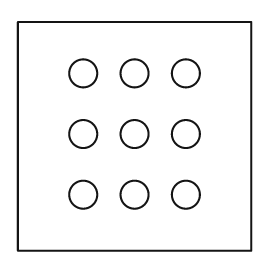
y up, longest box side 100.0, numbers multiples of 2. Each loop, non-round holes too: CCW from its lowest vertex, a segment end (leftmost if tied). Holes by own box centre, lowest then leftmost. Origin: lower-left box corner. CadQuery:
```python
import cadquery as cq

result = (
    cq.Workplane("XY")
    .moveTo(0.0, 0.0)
    .lineTo(100.0, 0.0)
    .lineTo(100.0, 98.0)
    .lineTo(0.0, 98.0)
    .close()
    .moveTo(28.0, 24.0)
    .circle(6.0)
    .moveTo(50.0, 24.0)
    .circle(6.0)
    .moveTo(72.0, 24.0)
    .circle(6.0)
    .moveTo(28.0, 50.0)
    .circle(6.0)
    .moveTo(50.0, 50.0)
    .circle(6.0)
    .moveTo(72.0, 50.0)
    .circle(6.0)
    .moveTo(28.0, 76.0)
    .circle(6.0)
    .moveTo(50.0, 76.0)
    .circle(6.0)
    .moveTo(72.0, 76.0)
    .circle(6.0)
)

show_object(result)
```